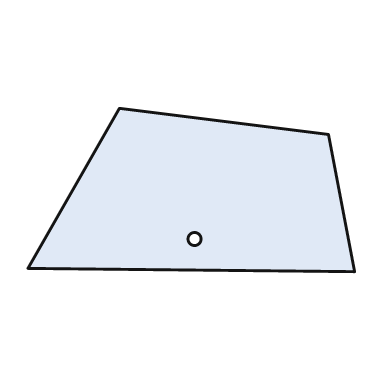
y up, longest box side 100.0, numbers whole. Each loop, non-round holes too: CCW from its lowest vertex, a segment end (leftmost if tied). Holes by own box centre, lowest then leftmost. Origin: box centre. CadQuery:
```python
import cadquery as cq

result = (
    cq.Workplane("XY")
    .moveTo(50.0, -25.0)
    .lineTo(42.0, 17.0)
    .lineTo(-22.0, 25.0)
    .lineTo(-50.0, -24.0)
    .close()
    .moveTo(1.0, -15.0)
    .circle(2.0)
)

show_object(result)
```